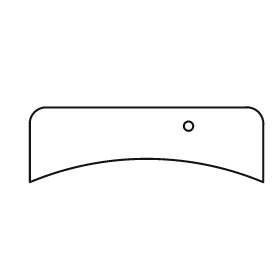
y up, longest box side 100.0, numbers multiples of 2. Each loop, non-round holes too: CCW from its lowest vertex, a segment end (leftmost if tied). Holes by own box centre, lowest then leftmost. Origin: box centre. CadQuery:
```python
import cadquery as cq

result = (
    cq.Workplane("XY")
    .moveTo(-50.0, -16.0)
    .threePointArc((0.0, -6.0), (50.0, -16.0))
    .lineTo(50.0, 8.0)
    .threePointArc((48.0, 14.0), (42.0, 16.0))
    .lineTo(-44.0, 16.0)
    .threePointArc((-48.0, 14.0), (-50.0, 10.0))
    .close()
    .moveTo(18.0, 8.0)
    .circle(2.0)
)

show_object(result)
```